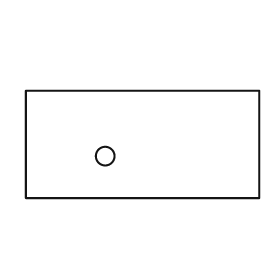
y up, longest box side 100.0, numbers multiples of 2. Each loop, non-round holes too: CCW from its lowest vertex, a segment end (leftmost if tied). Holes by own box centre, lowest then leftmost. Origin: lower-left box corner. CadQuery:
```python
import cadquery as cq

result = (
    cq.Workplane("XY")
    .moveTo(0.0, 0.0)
    .lineTo(100.0, 0.0)
    .lineTo(100.0, 46.0)
    .lineTo(0.0, 46.0)
    .close()
    .moveTo(34.0, 18.0)
    .circle(4.0)
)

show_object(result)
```